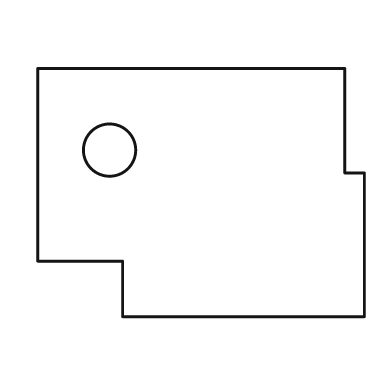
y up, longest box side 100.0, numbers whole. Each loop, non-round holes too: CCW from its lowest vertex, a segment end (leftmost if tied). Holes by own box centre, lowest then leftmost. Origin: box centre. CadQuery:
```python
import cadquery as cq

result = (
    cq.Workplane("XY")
    .moveTo(-24.0, -38.0)
    .lineTo(50.0, -38.0)
    .lineTo(50.0, 6.0)
    .lineTo(44.0, 6.0)
    .lineTo(44.0, 38.0)
    .lineTo(-50.0, 38.0)
    .lineTo(-50.0, -21.0)
    .lineTo(-24.0, -21.0)
    .close()
    .moveTo(-28.0, 13.0)
    .circle(8.0)
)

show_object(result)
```